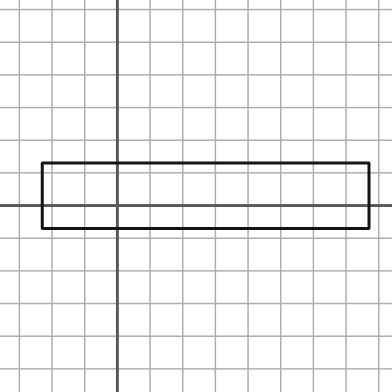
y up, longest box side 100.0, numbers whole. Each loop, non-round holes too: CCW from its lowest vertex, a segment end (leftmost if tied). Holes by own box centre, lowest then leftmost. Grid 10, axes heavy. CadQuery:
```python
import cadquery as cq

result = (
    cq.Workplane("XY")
    .moveTo(-23.0, -7.0)
    .lineTo(77.0, -7.0)
    .lineTo(77.0, 13.0)
    .lineTo(-23.0, 13.0)
    .close()
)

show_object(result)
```